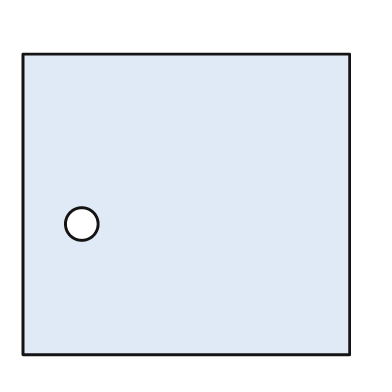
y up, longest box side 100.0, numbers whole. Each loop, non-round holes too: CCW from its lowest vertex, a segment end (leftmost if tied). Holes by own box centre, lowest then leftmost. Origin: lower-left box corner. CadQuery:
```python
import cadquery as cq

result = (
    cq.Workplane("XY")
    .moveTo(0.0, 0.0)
    .lineTo(100.0, 0.0)
    .lineTo(100.0, 92.0)
    .lineTo(0.0, 92.0)
    .close()
    .moveTo(18.0, 40.0)
    .circle(5.0)
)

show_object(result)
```